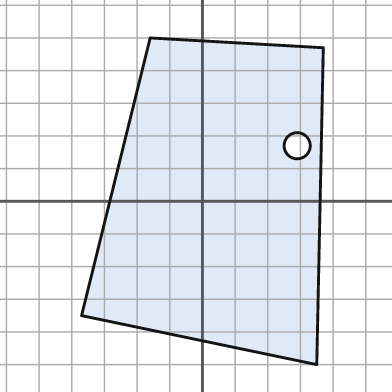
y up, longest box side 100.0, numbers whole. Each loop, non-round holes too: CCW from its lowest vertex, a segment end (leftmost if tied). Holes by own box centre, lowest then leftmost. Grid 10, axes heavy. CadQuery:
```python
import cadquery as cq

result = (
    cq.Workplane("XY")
    .moveTo(35.0, -50.0)
    .lineTo(37.0, 47.0)
    .lineTo(-16.0, 50.0)
    .lineTo(-37.0, -35.0)
    .close()
    .moveTo(29.0, 17.0)
    .circle(4.0)
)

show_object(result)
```